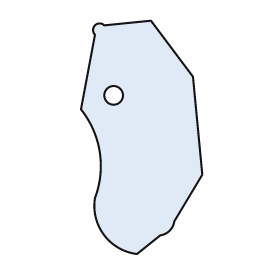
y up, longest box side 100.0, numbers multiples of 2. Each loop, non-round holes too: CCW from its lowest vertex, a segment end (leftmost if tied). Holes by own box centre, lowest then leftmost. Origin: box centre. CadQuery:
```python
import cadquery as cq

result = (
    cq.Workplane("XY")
    .moveTo(-2.0, -50.0)
    .lineTo(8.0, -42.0)
    .threePointArc((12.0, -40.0), (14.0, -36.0))
    .lineTo(26.0, -16.0)
    .lineTo(22.0, 26.0)
    .lineTo(4.0, 50.0)
    .lineTo(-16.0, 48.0)
    .threePointArc((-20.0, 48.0), (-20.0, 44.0))
    .lineTo(-26.0, 12.0)
    .threePointArc((-18.0, -6.0), (-20.0, -26.0))
    .threePointArc((-16.0, -42.0), (-2.0, -50.0))
    .close()
    .moveTo(-12.0, 18.0)
    .circle(4.0)
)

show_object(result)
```